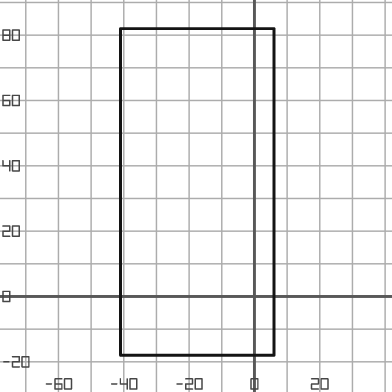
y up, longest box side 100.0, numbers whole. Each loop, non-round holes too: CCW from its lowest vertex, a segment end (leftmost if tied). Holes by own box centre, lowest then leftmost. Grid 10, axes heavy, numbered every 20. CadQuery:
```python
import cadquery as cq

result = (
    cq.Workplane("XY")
    .moveTo(-41.0, -18.0)
    .lineTo(6.0, -18.0)
    .lineTo(6.0, 82.0)
    .lineTo(-41.0, 82.0)
    .close()
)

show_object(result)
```